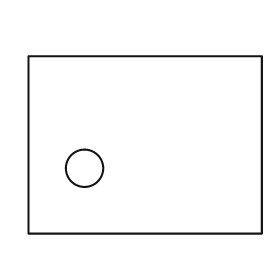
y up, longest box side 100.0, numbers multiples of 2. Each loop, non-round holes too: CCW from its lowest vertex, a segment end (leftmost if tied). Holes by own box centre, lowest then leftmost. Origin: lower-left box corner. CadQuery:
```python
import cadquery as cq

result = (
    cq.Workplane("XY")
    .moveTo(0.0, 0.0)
    .lineTo(100.0, 0.0)
    .lineTo(100.0, 76.0)
    .lineTo(0.0, 76.0)
    .close()
    .moveTo(24.0, 28.0)
    .circle(8.0)
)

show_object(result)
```